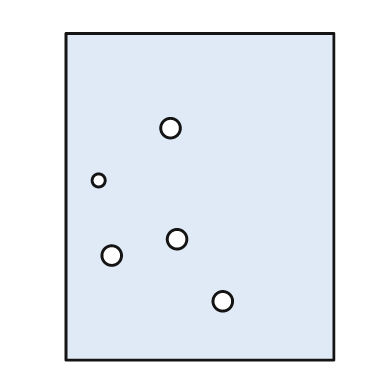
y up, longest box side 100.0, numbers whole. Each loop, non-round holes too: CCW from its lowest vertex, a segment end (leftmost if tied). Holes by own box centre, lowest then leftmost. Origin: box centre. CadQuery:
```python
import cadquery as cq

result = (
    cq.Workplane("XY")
    .moveTo(-41.0, -50.0)
    .lineTo(41.0, -50.0)
    .lineTo(41.0, 50.0)
    .lineTo(-41.0, 50.0)
    .close()
    .moveTo(7.0, -32.0)
    .circle(3.0)
    .moveTo(-27.0, -18.0)
    .circle(3.0)
    .moveTo(-7.0, -13.0)
    .circle(3.0)
    .moveTo(-31.0, 5.0)
    .circle(2.0)
    .moveTo(-9.0, 21.0)
    .circle(3.0)
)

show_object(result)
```